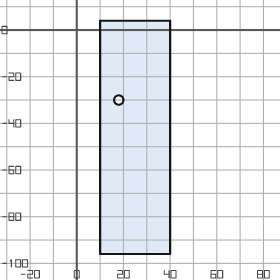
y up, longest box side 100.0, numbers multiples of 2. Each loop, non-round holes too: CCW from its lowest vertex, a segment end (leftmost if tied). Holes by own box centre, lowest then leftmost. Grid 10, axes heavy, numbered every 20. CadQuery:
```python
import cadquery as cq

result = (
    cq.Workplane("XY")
    .moveTo(10.0, -96.0)
    .lineTo(40.0, -96.0)
    .lineTo(40.0, 4.0)
    .lineTo(10.0, 4.0)
    .close()
    .moveTo(18.0, -30.0)
    .circle(2.0)
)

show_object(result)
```